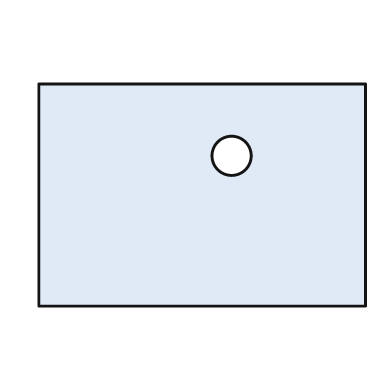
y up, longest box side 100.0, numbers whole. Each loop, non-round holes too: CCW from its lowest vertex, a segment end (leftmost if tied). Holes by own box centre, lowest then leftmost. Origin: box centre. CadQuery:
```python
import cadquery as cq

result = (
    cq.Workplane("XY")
    .moveTo(-50.0, -34.0)
    .lineTo(50.0, -34.0)
    .lineTo(50.0, 34.0)
    .lineTo(-50.0, 34.0)
    .close()
    .moveTo(9.0, 12.0)
    .circle(6.0)
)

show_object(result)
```